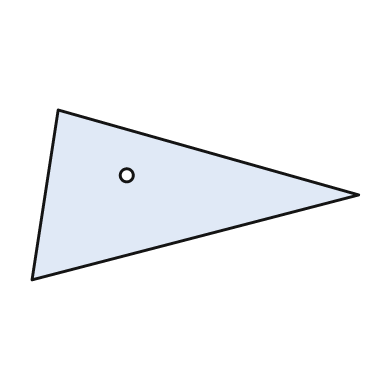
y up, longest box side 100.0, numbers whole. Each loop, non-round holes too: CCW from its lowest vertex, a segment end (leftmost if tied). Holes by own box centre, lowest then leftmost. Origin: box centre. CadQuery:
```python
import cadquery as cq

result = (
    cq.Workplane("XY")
    .moveTo(-50.0, -26.0)
    .lineTo(50.0, 0.0)
    .lineTo(-42.0, 26.0)
    .close()
    .moveTo(-21.0, 6.0)
    .circle(2.0)
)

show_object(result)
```